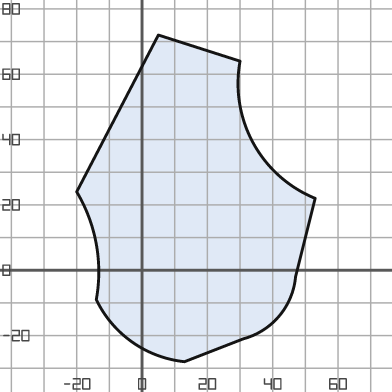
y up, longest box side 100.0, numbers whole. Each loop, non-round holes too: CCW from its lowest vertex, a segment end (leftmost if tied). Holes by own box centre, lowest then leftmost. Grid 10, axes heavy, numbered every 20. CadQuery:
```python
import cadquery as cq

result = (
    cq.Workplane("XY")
    .moveTo(13.0, -28.0)
    .lineTo(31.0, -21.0)
    .threePointArc((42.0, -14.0), (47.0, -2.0))
    .lineTo(53.0, 22.0)
    .threePointArc((34.0, 39.0), (30.0, 64.0))
    .lineTo(5.0, 72.0)
    .lineTo(-20.0, 24.0)
    .threePointArc((-14.0, 8.0), (-14.0, -9.0))
    .threePointArc((-3.0, -22.0), (13.0, -28.0))
    .close()
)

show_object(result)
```